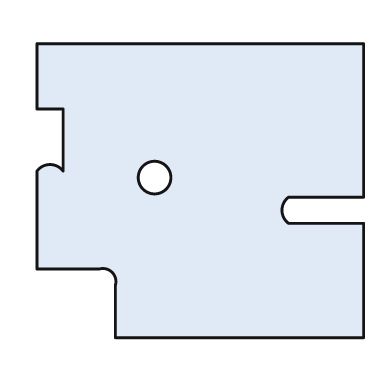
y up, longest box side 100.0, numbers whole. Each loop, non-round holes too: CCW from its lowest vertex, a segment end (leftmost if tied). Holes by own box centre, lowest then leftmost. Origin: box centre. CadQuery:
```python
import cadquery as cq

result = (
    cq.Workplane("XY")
    .moveTo(-26.0, -45.0)
    .lineTo(50.0, -45.0)
    .lineTo(50.0, -10.0)
    .lineTo(27.0, -10.0)
    .threePointArc((25.0, -6.0), (27.0, -2.0))
    .lineTo(50.0, -2.0)
    .lineTo(50.0, 45.0)
    .lineTo(-50.0, 45.0)
    .lineTo(-50.0, 25.0)
    .lineTo(-42.0, 25.0)
    .lineTo(-42.0, 6.0)
    .threePointArc((-46.0, 8.0), (-50.0, 6.0))
    .lineTo(-50.0, -24.0)
    .lineTo(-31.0, -24.0)
    .threePointArc((-27.0, -25.0), (-26.0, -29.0))
    .close()
    .moveTo(-14.0, 4.0)
    .circle(5.0)
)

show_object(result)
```